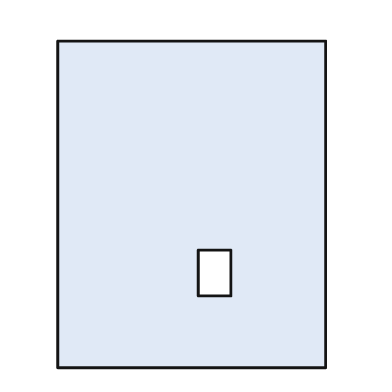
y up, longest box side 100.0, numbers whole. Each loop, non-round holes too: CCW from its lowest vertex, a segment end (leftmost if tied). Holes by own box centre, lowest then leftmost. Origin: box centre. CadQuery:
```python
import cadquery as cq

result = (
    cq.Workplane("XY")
    .moveTo(-41.0, -50.0)
    .lineTo(41.0, -50.0)
    .lineTo(41.0, 50.0)
    .lineTo(-41.0, 50.0)
    .close()
    .moveTo(2.0, -28.0)
    .lineTo(12.0, -28.0)
    .lineTo(12.0, -14.0)
    .lineTo(2.0, -14.0)
    .close()
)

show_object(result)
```